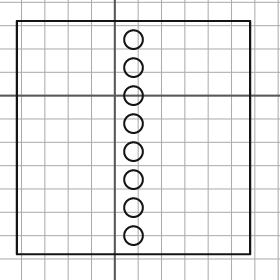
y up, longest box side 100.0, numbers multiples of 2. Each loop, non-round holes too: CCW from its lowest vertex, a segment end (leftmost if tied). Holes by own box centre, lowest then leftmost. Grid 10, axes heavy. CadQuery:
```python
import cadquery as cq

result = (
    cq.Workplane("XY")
    .moveTo(-42.0, -68.0)
    .lineTo(58.0, -68.0)
    .lineTo(58.0, 32.0)
    .lineTo(-42.0, 32.0)
    .close()
    .moveTo(8.0, -60.0)
    .circle(4.0)
    .moveTo(8.0, -48.0)
    .circle(4.0)
    .moveTo(8.0, -36.0)
    .circle(4.0)
    .moveTo(8.0, -24.0)
    .circle(4.0)
    .moveTo(8.0, -12.0)
    .circle(4.0)
    .moveTo(8.0, 0.0)
    .circle(4.0)
    .moveTo(8.0, 12.0)
    .circle(4.0)
    .moveTo(8.0, 24.0)
    .circle(4.0)
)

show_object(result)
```